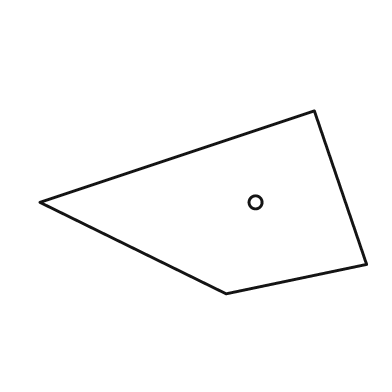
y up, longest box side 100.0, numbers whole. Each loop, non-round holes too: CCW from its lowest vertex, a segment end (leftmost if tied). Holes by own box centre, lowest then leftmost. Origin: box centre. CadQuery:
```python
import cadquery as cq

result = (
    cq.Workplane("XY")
    .moveTo(7.0, -28.0)
    .lineTo(50.0, -19.0)
    .lineTo(34.0, 28.0)
    .lineTo(-50.0, 0.0)
    .close()
    .moveTo(16.0, 0.0)
    .circle(2.0)
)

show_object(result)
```